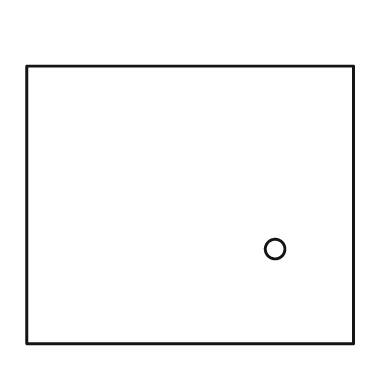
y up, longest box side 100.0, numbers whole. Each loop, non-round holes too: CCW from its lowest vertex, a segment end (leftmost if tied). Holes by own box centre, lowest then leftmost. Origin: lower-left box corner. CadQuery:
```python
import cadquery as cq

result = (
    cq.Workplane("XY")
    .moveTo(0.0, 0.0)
    .lineTo(100.0, 0.0)
    .lineTo(100.0, 85.0)
    .lineTo(0.0, 85.0)
    .close()
    .moveTo(76.0, 29.0)
    .circle(3.0)
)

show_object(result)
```